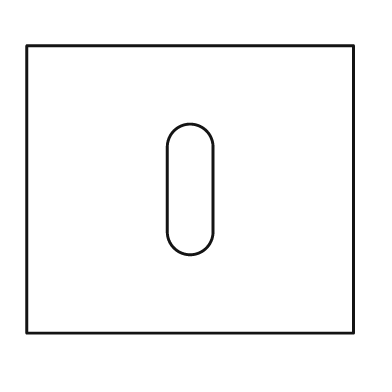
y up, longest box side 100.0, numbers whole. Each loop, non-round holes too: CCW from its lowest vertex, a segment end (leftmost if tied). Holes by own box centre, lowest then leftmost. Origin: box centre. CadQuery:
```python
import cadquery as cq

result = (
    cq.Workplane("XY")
    .moveTo(-50.0, -44.0)
    .lineTo(50.0, -44.0)
    .lineTo(50.0, 44.0)
    .lineTo(-50.0, 44.0)
    .close()
    .moveTo(-7.0, -13.0)
    .threePointArc((0.0, -20.0), (7.0, -13.0))
    .lineTo(7.0, 13.0)
    .threePointArc((0.0, 20.0), (-7.0, 13.0))
    .close()
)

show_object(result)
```